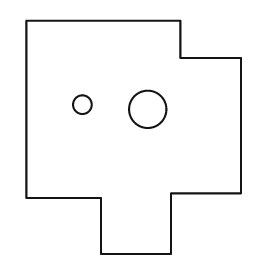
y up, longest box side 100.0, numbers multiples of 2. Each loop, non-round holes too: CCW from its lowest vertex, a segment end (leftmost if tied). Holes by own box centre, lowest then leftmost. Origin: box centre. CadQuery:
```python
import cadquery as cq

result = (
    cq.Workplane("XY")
    .moveTo(-14.0, -50.0)
    .lineTo(16.0, -50.0)
    .lineTo(16.0, -24.0)
    .lineTo(46.0, -24.0)
    .lineTo(46.0, 34.0)
    .lineTo(20.0, 34.0)
    .lineTo(20.0, 50.0)
    .lineTo(-46.0, 50.0)
    .lineTo(-46.0, -26.0)
    .lineTo(-14.0, -26.0)
    .close()
    .moveTo(6.0, 12.0)
    .circle(8.0)
    .moveTo(-22.0, 14.0)
    .circle(4.0)
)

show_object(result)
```